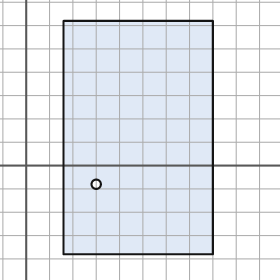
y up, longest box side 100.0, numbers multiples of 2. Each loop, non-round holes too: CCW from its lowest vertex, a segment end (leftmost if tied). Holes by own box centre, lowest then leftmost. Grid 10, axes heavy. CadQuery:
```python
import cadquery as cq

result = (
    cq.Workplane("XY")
    .moveTo(16.0, -38.0)
    .lineTo(80.0, -38.0)
    .lineTo(80.0, 62.0)
    .lineTo(16.0, 62.0)
    .close()
    .moveTo(30.0, -8.0)
    .circle(2.0)
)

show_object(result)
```